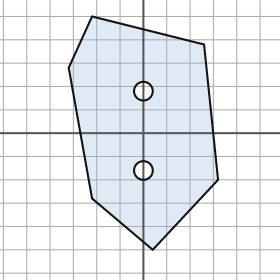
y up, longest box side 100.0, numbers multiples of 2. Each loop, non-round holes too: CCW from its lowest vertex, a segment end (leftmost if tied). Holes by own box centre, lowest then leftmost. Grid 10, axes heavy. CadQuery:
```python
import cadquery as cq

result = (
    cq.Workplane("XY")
    .moveTo(4.0, -50.0)
    .lineTo(32.0, -20.0)
    .lineTo(26.0, 38.0)
    .lineTo(-22.0, 50.0)
    .lineTo(-32.0, 28.0)
    .lineTo(-22.0, -28.0)
    .close()
    .moveTo(0.0, -16.0)
    .circle(4.0)
    .moveTo(0.0, 18.0)
    .circle(4.0)
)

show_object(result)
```